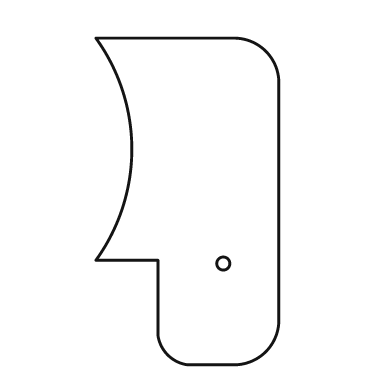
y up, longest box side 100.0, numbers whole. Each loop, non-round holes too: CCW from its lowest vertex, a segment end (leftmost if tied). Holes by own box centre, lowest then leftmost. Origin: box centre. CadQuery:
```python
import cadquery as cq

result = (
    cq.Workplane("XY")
    .moveTo(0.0, -50.0)
    .lineTo(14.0, -50.0)
    .threePointArc((24.0, -46.0), (28.0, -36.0))
    .lineTo(28.0, 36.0)
    .threePointArc((24.0, 46.0), (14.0, 50.0))
    .lineTo(-28.0, 50.0)
    .threePointArc((-17.0, 16.0), (-28.0, -18.0))
    .lineTo(-9.0, -18.0)
    .lineTo(-9.0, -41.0)
    .threePointArc((-6.0, -47.0), (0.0, -50.0))
    .close()
    .moveTo(11.0, -19.0)
    .circle(2.0)
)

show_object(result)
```